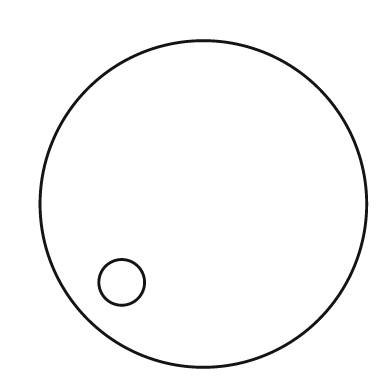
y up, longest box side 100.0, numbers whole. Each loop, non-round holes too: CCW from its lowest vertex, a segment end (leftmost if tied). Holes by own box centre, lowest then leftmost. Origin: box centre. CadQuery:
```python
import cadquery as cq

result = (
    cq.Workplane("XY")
    .moveTo(0.0, 0.0)
    .circle(50.0)
    .moveTo(-25.0, -24.0)
    .circle(7.0)
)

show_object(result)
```